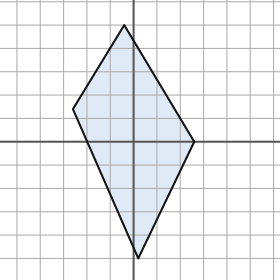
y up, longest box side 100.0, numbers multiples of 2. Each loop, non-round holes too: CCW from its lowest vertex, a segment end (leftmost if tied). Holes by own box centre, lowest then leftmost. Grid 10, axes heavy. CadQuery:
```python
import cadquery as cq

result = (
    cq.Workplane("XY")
    .moveTo(2.0, -50.0)
    .lineTo(26.0, 0.0)
    .lineTo(-4.0, 50.0)
    .lineTo(-26.0, 14.0)
    .close()
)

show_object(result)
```